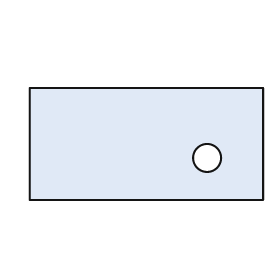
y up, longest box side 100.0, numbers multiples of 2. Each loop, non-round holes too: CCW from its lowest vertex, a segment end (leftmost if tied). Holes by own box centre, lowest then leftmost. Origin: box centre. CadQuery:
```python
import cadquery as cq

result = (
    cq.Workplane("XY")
    .moveTo(-50.0, -24.0)
    .lineTo(50.0, -24.0)
    .lineTo(50.0, 24.0)
    .lineTo(-50.0, 24.0)
    .close()
    .moveTo(26.0, -6.0)
    .circle(6.0)
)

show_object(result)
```